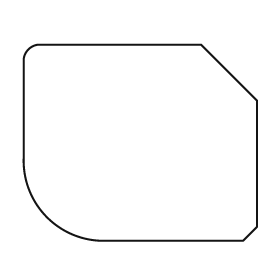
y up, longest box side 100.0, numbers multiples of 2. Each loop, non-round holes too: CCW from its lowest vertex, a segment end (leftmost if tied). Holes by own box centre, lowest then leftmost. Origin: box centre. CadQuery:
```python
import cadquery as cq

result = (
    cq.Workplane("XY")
    .moveTo(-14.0, -42.0)
    .lineTo(44.0, -42.0)
    .lineTo(50.0, -36.0)
    .lineTo(50.0, 18.0)
    .lineTo(26.0, 42.0)
    .lineTo(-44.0, 42.0)
    .threePointArc((-48.0, 40.0), (-50.0, 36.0))
    .lineTo(-50.0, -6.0)
    .threePointArc((-40.0, -32.0), (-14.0, -42.0))
    .close()
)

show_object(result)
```